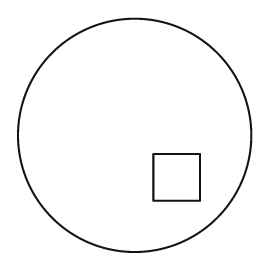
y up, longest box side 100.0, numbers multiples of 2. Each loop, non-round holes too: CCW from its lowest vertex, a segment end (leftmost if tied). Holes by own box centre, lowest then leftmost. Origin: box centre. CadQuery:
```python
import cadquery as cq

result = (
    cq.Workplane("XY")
    .moveTo(0.0, 0.0)
    .circle(50.0)
    .moveTo(8.0, -28.0)
    .lineTo(28.0, -28.0)
    .lineTo(28.0, -8.0)
    .lineTo(8.0, -8.0)
    .close()
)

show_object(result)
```